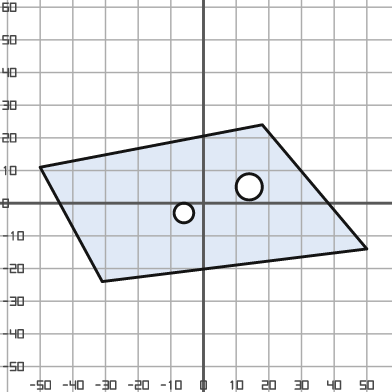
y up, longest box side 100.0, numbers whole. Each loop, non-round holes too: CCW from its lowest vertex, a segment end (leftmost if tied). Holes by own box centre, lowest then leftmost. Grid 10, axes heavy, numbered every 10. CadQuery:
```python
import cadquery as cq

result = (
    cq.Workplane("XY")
    .moveTo(-31.0, -24.0)
    .lineTo(50.0, -14.0)
    .lineTo(18.0, 24.0)
    .lineTo(-50.0, 11.0)
    .close()
    .moveTo(-6.0, -3.0)
    .circle(3.0)
    .moveTo(14.0, 5.0)
    .circle(4.0)
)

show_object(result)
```